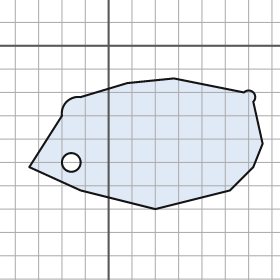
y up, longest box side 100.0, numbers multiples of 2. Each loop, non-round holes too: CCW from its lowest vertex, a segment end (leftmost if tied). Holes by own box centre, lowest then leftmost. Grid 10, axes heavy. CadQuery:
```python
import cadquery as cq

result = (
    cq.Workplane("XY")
    .moveTo(20.0, -70.0)
    .lineTo(52.0, -62.0)
    .lineTo(62.0, -52.0)
    .lineTo(66.0, -42.0)
    .lineTo(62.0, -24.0)
    .threePointArc((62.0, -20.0), (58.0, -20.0))
    .lineTo(28.0, -14.0)
    .lineTo(8.0, -16.0)
    .lineTo(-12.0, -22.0)
    .threePointArc((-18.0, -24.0), (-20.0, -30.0))
    .lineTo(-34.0, -52.0)
    .lineTo(-12.0, -62.0)
    .close()
    .moveTo(-16.0, -50.0)
    .circle(4.0)
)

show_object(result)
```